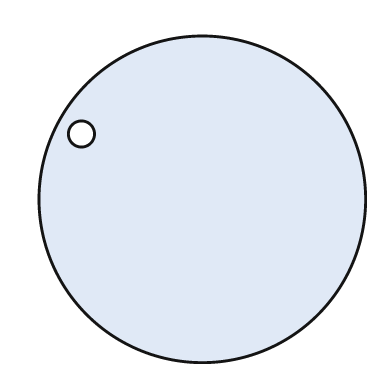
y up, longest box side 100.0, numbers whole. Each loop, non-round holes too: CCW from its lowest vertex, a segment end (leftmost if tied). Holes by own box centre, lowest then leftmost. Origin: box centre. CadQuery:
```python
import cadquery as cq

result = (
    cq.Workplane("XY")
    .moveTo(0.0, 0.0)
    .circle(50.0)
    .moveTo(-37.0, 20.0)
    .circle(4.0)
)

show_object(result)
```